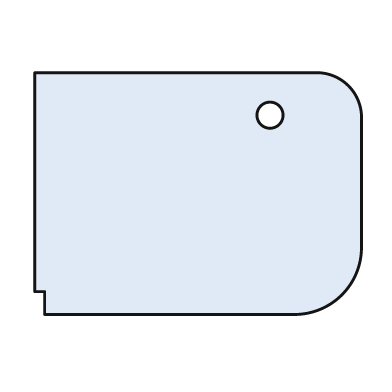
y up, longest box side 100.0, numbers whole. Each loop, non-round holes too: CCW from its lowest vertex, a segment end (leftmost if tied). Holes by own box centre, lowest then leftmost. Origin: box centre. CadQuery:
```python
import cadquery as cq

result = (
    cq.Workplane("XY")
    .moveTo(-47.0, -37.0)
    .lineTo(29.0, -37.0)
    .threePointArc((44.0, -31.0), (50.0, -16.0))
    .lineTo(50.0, 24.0)
    .threePointArc((46.0, 33.0), (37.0, 37.0))
    .lineTo(-50.0, 37.0)
    .lineTo(-50.0, -30.0)
    .lineTo(-47.0, -30.0)
    .close()
    .moveTo(22.0, 24.0)
    .circle(4.0)
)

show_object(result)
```